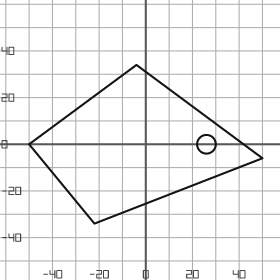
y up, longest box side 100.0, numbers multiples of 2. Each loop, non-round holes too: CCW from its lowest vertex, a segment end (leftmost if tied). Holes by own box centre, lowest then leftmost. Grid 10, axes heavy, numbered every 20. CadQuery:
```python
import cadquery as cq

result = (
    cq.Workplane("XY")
    .moveTo(-22.0, -34.0)
    .lineTo(50.0, -6.0)
    .lineTo(-4.0, 34.0)
    .lineTo(-50.0, 0.0)
    .close()
    .moveTo(26.0, 0.0)
    .circle(4.0)
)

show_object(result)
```